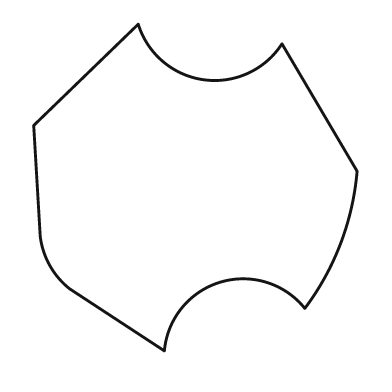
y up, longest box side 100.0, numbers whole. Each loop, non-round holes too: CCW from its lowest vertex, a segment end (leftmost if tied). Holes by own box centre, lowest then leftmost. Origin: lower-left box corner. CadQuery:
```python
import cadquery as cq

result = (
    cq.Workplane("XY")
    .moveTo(40.0, 0.0)
    .threePointArc((57.0, 21.0), (83.0, 13.0))
    .threePointArc((94.0, 33.0), (99.0, 55.0))
    .lineTo(76.0, 94.0)
    .threePointArc((52.0, 83.0), (32.0, 100.0))
    .lineTo(0.0, 69.0)
    .lineTo(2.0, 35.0)
    .threePointArc((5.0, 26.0), (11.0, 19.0))
    .close()
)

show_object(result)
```